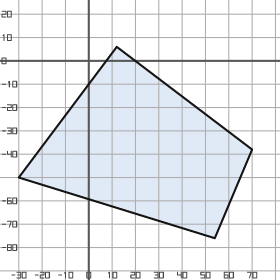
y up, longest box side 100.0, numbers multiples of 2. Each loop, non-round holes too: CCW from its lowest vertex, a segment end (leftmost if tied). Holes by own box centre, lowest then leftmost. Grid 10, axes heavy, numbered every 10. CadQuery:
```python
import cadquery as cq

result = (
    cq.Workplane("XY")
    .moveTo(54.0, -76.0)
    .lineTo(70.0, -38.0)
    .lineTo(12.0, 6.0)
    .lineTo(-30.0, -50.0)
    .close()
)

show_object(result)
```